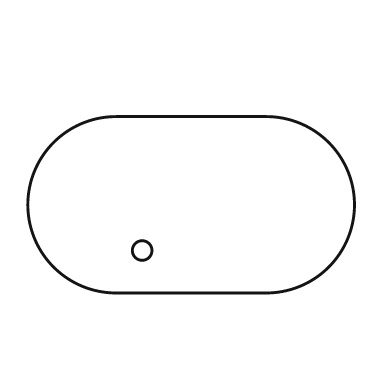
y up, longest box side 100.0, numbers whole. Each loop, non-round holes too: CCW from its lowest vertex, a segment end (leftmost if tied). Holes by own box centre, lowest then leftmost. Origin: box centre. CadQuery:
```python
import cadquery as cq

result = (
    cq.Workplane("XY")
    .moveTo(-23.0, -27.0)
    .lineTo(23.0, -27.0)
    .threePointArc((50.0, 0.0), (23.0, 27.0))
    .lineTo(-23.0, 27.0)
    .threePointArc((-50.0, 0.0), (-23.0, -27.0))
    .close()
    .moveTo(-15.0, -14.0)
    .circle(3.0)
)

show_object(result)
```